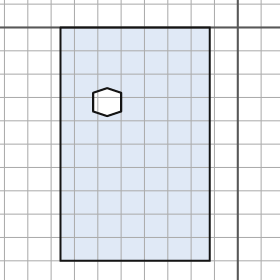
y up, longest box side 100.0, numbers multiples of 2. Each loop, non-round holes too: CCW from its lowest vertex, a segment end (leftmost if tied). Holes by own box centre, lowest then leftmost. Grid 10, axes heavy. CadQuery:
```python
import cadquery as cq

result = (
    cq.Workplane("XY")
    .moveTo(-76.0, -100.0)
    .lineTo(-12.0, -100.0)
    .lineTo(-12.0, 0.0)
    .lineTo(-76.0, 0.0)
    .close()
    .moveTo(-56.0, -38.0)
    .lineTo(-50.0, -36.0)
    .lineTo(-50.0, -28.0)
    .lineTo(-56.0, -26.0)
    .lineTo(-62.0, -28.0)
    .lineTo(-62.0, -36.0)
    .close()
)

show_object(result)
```